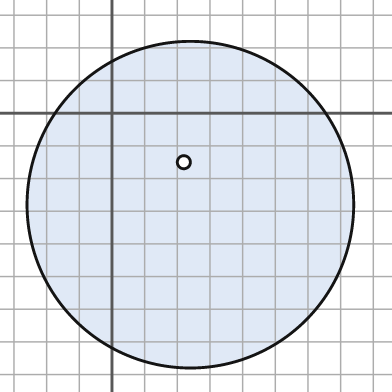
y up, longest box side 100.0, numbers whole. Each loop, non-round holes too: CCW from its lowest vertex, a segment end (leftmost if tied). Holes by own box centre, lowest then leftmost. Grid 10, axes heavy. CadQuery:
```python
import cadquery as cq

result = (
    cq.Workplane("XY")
    .moveTo(24.0, -28.0)
    .circle(50.0)
    .moveTo(22.0, -15.0)
    .circle(2.0)
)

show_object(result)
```